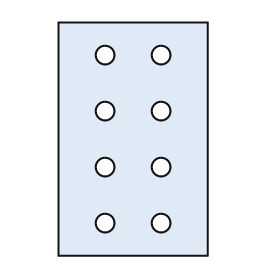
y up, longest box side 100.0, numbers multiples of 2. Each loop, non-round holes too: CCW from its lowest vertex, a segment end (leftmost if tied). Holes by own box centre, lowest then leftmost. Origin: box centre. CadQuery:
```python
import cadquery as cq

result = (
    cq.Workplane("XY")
    .moveTo(-32.0, -50.0)
    .lineTo(32.0, -50.0)
    .lineTo(32.0, 50.0)
    .lineTo(-32.0, 50.0)
    .close()
    .moveTo(-12.0, -36.0)
    .circle(4.0)
    .moveTo(12.0, -36.0)
    .circle(4.0)
    .moveTo(-12.0, -12.0)
    .circle(4.0)
    .moveTo(12.0, -12.0)
    .circle(4.0)
    .moveTo(-12.0, 12.0)
    .circle(4.0)
    .moveTo(12.0, 12.0)
    .circle(4.0)
    .moveTo(-12.0, 36.0)
    .circle(4.0)
    .moveTo(12.0, 36.0)
    .circle(4.0)
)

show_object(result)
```